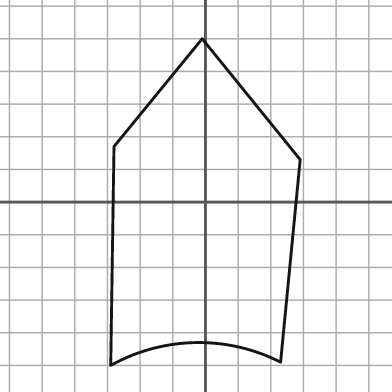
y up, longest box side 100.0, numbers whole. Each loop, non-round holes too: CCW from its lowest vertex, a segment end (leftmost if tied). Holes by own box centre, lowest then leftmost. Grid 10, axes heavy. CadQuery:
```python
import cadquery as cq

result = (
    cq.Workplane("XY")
    .moveTo(-29.0, -50.0)
    .threePointArc((-3.0, -43.0), (23.0, -49.0))
    .lineTo(29.0, 13.0)
    .lineTo(-1.0, 50.0)
    .lineTo(-28.0, 17.0)
    .close()
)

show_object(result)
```